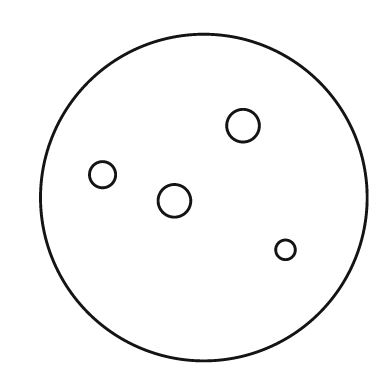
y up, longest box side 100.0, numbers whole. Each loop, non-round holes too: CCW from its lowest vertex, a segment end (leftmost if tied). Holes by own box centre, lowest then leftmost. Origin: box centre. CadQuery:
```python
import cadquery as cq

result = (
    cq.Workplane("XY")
    .moveTo(0.0, 0.0)
    .circle(50.0)
    .moveTo(25.0, -16.0)
    .circle(3.0)
    .moveTo(-9.0, -1.0)
    .circle(5.0)
    .moveTo(-31.0, 7.0)
    .circle(4.0)
    .moveTo(12.0, 22.0)
    .circle(5.0)
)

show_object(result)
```